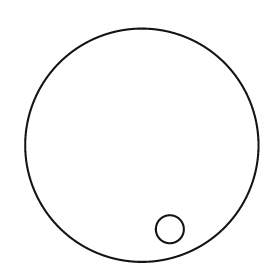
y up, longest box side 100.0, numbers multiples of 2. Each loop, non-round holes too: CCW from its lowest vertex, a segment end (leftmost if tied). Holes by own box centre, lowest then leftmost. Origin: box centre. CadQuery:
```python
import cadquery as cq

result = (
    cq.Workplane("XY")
    .moveTo(0.0, 0.0)
    .circle(50.0)
    .moveTo(12.0, -36.0)
    .circle(6.0)
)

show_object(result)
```